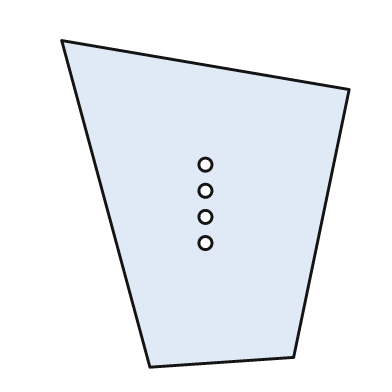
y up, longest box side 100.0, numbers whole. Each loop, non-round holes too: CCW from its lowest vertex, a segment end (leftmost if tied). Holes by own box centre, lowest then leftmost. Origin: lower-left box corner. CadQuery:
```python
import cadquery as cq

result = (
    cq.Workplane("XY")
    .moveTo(27.0, 0.0)
    .lineTo(71.0, 3.0)
    .lineTo(88.0, 85.0)
    .lineTo(0.0, 100.0)
    .close()
    .moveTo(44.0, 38.0)
    .circle(2.0)
    .moveTo(44.0, 46.0)
    .circle(2.0)
    .moveTo(44.0, 54.0)
    .circle(2.0)
    .moveTo(44.0, 62.0)
    .circle(2.0)
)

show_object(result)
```